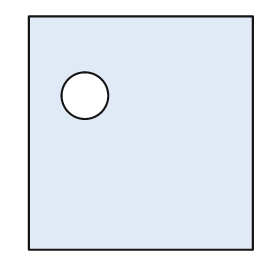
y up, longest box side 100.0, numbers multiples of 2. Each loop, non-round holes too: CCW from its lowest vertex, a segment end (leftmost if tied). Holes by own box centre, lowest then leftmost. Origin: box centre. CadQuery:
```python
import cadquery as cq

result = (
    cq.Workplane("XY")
    .moveTo(-48.0, -50.0)
    .lineTo(48.0, -50.0)
    .lineTo(48.0, 50.0)
    .lineTo(-48.0, 50.0)
    .close()
    .moveTo(-24.0, 16.0)
    .circle(10.0)
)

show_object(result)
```